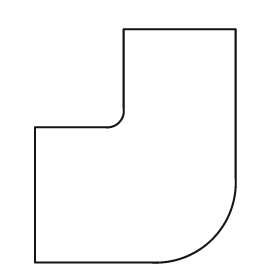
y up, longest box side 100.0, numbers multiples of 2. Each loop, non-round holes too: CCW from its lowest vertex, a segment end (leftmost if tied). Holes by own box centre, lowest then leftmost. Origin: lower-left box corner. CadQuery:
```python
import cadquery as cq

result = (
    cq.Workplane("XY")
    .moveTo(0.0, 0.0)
    .lineTo(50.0, 0.0)
    .threePointArc((76.0, 10.0), (86.0, 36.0))
    .lineTo(86.0, 100.0)
    .lineTo(38.0, 100.0)
    .lineTo(38.0, 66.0)
    .threePointArc((36.0, 60.0), (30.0, 58.0))
    .lineTo(0.0, 58.0)
    .close()
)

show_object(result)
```